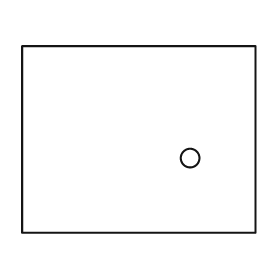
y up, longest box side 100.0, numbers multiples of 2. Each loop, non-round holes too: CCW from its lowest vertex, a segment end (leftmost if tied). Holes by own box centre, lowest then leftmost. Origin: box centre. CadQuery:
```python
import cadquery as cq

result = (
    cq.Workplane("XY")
    .moveTo(-50.0, -40.0)
    .lineTo(50.0, -40.0)
    .lineTo(50.0, 40.0)
    .lineTo(-50.0, 40.0)
    .close()
    .moveTo(22.0, -8.0)
    .circle(4.0)
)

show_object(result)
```